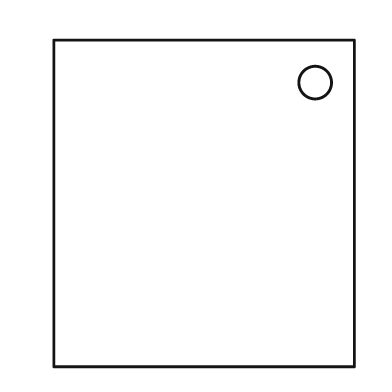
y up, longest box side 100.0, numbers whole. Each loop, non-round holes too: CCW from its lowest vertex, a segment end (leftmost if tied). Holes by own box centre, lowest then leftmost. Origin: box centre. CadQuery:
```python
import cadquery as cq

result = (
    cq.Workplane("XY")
    .moveTo(-46.0, -50.0)
    .lineTo(46.0, -50.0)
    .lineTo(46.0, 50.0)
    .lineTo(-46.0, 50.0)
    .close()
    .moveTo(34.0, 37.0)
    .circle(5.0)
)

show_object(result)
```